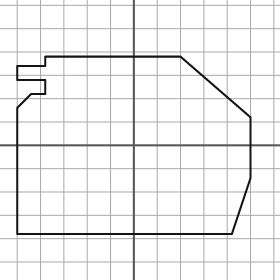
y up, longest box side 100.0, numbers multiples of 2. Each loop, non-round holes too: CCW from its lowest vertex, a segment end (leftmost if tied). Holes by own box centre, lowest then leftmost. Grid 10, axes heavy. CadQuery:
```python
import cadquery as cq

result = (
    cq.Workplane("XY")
    .moveTo(-50.0, -38.0)
    .lineTo(42.0, -38.0)
    .lineTo(50.0, -14.0)
    .lineTo(50.0, 12.0)
    .lineTo(20.0, 38.0)
    .lineTo(-38.0, 38.0)
    .lineTo(-38.0, 34.0)
    .lineTo(-50.0, 34.0)
    .lineTo(-50.0, 28.0)
    .lineTo(-38.0, 28.0)
    .lineTo(-38.0, 22.0)
    .lineTo(-44.0, 22.0)
    .lineTo(-50.0, 16.0)
    .close()
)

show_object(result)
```